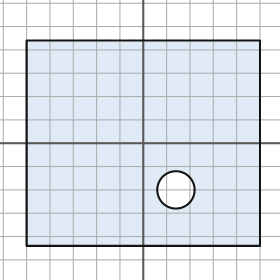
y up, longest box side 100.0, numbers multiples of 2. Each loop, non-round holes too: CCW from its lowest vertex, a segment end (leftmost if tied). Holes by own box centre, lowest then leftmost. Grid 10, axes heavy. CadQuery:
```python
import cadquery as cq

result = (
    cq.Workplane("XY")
    .moveTo(-50.0, -44.0)
    .lineTo(50.0, -44.0)
    .lineTo(50.0, 44.0)
    .lineTo(-50.0, 44.0)
    .close()
    .moveTo(14.0, -20.0)
    .circle(8.0)
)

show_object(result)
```